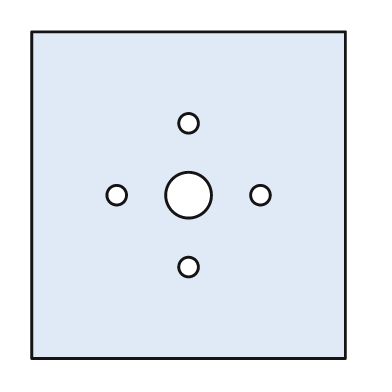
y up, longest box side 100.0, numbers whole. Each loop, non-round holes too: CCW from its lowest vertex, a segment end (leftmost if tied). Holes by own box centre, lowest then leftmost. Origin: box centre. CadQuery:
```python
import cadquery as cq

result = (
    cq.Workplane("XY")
    .moveTo(-48.0, -50.0)
    .lineTo(48.0, -50.0)
    .lineTo(48.0, 50.0)
    .lineTo(-48.0, 50.0)
    .close()
    .moveTo(0.0, -22.0)
    .circle(3.0)
    .moveTo(-22.0, 0.0)
    .circle(3.0)
    .moveTo(0.0, 0.0)
    .circle(7.0)
    .moveTo(22.0, 0.0)
    .circle(3.0)
    .moveTo(0.0, 22.0)
    .circle(3.0)
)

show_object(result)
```